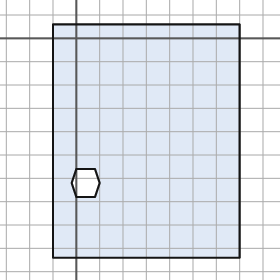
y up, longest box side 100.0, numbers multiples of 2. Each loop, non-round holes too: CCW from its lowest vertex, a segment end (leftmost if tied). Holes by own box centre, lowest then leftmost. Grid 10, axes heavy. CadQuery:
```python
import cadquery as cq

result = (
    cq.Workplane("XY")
    .moveTo(-10.0, -94.0)
    .lineTo(70.0, -94.0)
    .lineTo(70.0, 6.0)
    .lineTo(-10.0, 6.0)
    .close()
    .moveTo(0.0, -68.0)
    .lineTo(8.0, -68.0)
    .lineTo(10.0, -62.0)
    .lineTo(8.0, -56.0)
    .lineTo(0.0, -56.0)
    .lineTo(-2.0, -62.0)
    .close()
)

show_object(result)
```